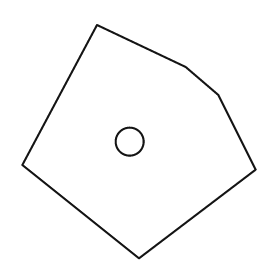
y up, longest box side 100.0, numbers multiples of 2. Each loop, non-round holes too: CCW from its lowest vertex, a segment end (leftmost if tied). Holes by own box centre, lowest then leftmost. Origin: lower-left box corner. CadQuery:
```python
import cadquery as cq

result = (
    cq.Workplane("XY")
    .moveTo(50.0, 0.0)
    .lineTo(100.0, 38.0)
    .lineTo(84.0, 70.0)
    .lineTo(70.0, 82.0)
    .lineTo(32.0, 100.0)
    .lineTo(0.0, 40.0)
    .close()
    .moveTo(46.0, 50.0)
    .circle(6.0)
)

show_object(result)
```